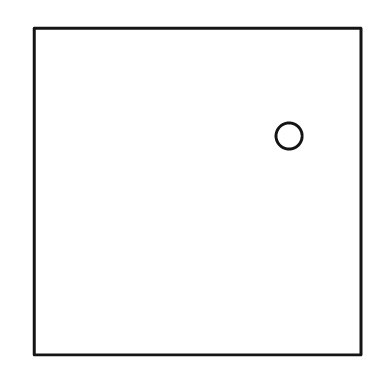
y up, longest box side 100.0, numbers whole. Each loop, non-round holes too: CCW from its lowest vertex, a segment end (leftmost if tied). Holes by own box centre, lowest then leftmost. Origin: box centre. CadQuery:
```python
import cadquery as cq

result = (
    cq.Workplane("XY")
    .moveTo(-50.0, -50.0)
    .lineTo(50.0, -50.0)
    .lineTo(50.0, 50.0)
    .lineTo(-50.0, 50.0)
    .close()
    .moveTo(28.0, 17.0)
    .circle(4.0)
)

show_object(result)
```